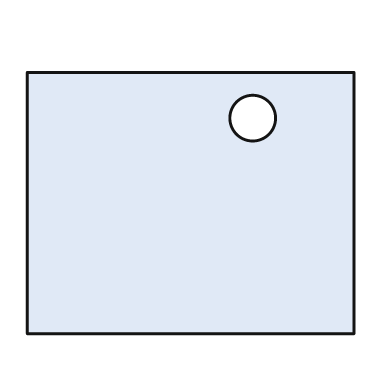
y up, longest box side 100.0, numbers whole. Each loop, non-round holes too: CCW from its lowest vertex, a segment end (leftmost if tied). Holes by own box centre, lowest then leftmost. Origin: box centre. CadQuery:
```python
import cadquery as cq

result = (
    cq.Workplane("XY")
    .moveTo(-50.0, -40.0)
    .lineTo(50.0, -40.0)
    .lineTo(50.0, 40.0)
    .lineTo(-50.0, 40.0)
    .close()
    .moveTo(19.0, 26.0)
    .circle(7.0)
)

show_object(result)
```